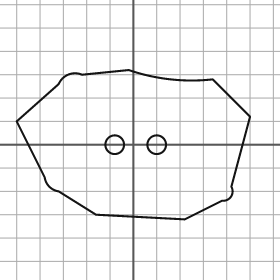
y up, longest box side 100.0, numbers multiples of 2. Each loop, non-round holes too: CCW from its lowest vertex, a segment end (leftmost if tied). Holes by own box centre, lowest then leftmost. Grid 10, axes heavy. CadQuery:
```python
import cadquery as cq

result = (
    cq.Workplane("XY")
    .moveTo(22.0, -32.0)
    .lineTo(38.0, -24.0)
    .threePointArc((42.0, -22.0), (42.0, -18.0))
    .lineTo(50.0, 12.0)
    .lineTo(34.0, 28.0)
    .threePointArc((16.0, 28.0), (-2.0, 32.0))
    .lineTo(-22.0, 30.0)
    .threePointArc((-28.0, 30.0), (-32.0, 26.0))
    .lineTo(-50.0, 10.0)
    .lineTo(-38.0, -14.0)
    .threePointArc((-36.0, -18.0), (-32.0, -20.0))
    .lineTo(-16.0, -30.0)
    .close()
    .moveTo(-8.0, 0.0)
    .circle(4.0)
    .moveTo(10.0, 0.0)
    .circle(4.0)
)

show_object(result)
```